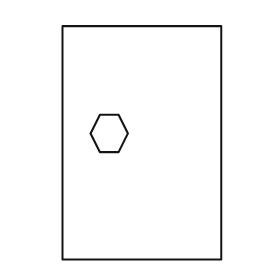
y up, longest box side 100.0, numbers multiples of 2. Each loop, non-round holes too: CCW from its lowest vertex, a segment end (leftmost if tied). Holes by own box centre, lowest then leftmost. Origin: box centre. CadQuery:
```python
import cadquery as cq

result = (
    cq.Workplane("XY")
    .moveTo(-34.0, -50.0)
    .lineTo(34.0, -50.0)
    .lineTo(34.0, 50.0)
    .lineTo(-34.0, 50.0)
    .close()
    .moveTo(-18.0, -4.0)
    .lineTo(-10.0, -4.0)
    .lineTo(-6.0, 4.0)
    .lineTo(-10.0, 12.0)
    .lineTo(-18.0, 12.0)
    .lineTo(-22.0, 4.0)
    .close()
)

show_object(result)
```